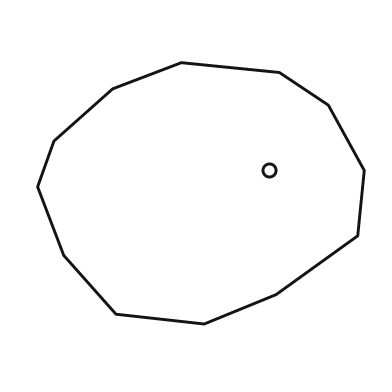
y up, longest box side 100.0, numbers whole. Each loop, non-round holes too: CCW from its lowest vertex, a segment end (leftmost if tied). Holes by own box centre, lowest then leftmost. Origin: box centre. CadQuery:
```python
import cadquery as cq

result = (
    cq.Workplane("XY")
    .moveTo(1.0, -40.0)
    .lineTo(23.0, -31.0)
    .lineTo(48.0, -13.0)
    .lineTo(50.0, 7.0)
    .lineTo(39.0, 27.0)
    .lineTo(24.0, 37.0)
    .lineTo(-6.0, 40.0)
    .lineTo(-27.0, 32.0)
    .lineTo(-45.0, 16.0)
    .lineTo(-50.0, 2.0)
    .lineTo(-42.0, -19.0)
    .lineTo(-26.0, -37.0)
    .close()
    .moveTo(21.0, 7.0)
    .circle(2.0)
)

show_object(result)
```